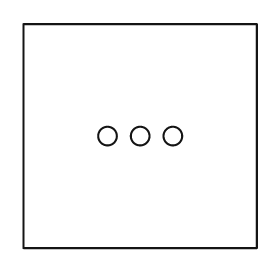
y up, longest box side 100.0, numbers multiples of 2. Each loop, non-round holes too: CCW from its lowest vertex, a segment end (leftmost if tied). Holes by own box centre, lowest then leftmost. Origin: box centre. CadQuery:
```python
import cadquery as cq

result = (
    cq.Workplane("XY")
    .moveTo(-50.0, -48.0)
    .lineTo(50.0, -48.0)
    .lineTo(50.0, 48.0)
    .lineTo(-50.0, 48.0)
    .close()
    .moveTo(-14.0, 0.0)
    .circle(4.0)
    .moveTo(0.0, 0.0)
    .circle(4.0)
    .moveTo(14.0, 0.0)
    .circle(4.0)
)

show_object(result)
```